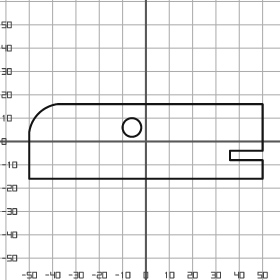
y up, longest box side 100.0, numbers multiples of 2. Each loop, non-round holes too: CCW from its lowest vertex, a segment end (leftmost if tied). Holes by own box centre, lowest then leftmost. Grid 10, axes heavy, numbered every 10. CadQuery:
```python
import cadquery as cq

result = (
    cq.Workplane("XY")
    .moveTo(-50.0, -16.0)
    .lineTo(50.0, -16.0)
    .lineTo(50.0, -8.0)
    .lineTo(36.0, -8.0)
    .lineTo(36.0, -4.0)
    .lineTo(50.0, -4.0)
    .lineTo(50.0, 16.0)
    .lineTo(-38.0, 16.0)
    .threePointArc((-46.0, 12.0), (-50.0, 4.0))
    .close()
    .moveTo(-6.0, 6.0)
    .circle(4.0)
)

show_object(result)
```